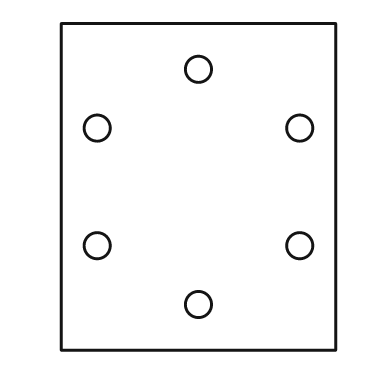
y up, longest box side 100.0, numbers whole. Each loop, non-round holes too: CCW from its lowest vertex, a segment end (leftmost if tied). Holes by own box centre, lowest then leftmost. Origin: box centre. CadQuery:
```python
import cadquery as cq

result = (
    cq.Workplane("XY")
    .moveTo(-42.0, -50.0)
    .lineTo(42.0, -50.0)
    .lineTo(42.0, 50.0)
    .lineTo(-42.0, 50.0)
    .close()
    .moveTo(0.0, -36.0)
    .circle(4.0)
    .moveTo(-31.0, -18.0)
    .circle(4.0)
    .moveTo(31.0, -18.0)
    .circle(4.0)
    .moveTo(-31.0, 18.0)
    .circle(4.0)
    .moveTo(31.0, 18.0)
    .circle(4.0)
    .moveTo(0.0, 36.0)
    .circle(4.0)
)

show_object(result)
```